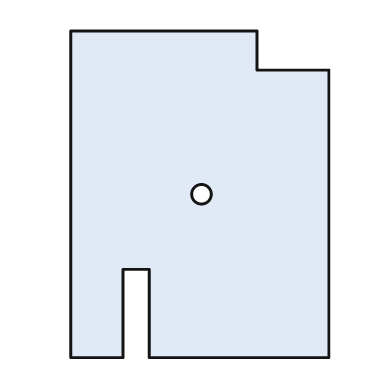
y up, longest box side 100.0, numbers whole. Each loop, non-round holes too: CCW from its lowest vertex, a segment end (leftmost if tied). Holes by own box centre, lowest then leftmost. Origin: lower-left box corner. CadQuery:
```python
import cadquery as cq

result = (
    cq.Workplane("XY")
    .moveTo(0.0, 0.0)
    .lineTo(16.0, 0.0)
    .lineTo(16.0, 27.0)
    .lineTo(24.0, 27.0)
    .lineTo(24.0, 0.0)
    .lineTo(79.0, 0.0)
    .lineTo(79.0, 88.0)
    .lineTo(57.0, 88.0)
    .lineTo(57.0, 100.0)
    .lineTo(0.0, 100.0)
    .close()
    .moveTo(40.0, 50.0)
    .circle(3.0)
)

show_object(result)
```